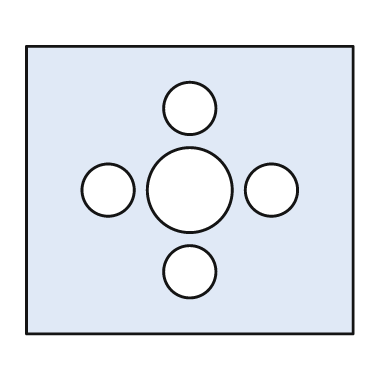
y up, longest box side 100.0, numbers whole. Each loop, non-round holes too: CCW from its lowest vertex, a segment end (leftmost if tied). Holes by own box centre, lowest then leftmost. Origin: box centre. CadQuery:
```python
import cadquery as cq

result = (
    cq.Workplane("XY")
    .moveTo(-50.0, -44.0)
    .lineTo(50.0, -44.0)
    .lineTo(50.0, 44.0)
    .lineTo(-50.0, 44.0)
    .close()
    .moveTo(0.0, -25.0)
    .circle(8.0)
    .moveTo(-25.0, 0.0)
    .circle(8.0)
    .moveTo(0.0, 0.0)
    .circle(13.0)
    .moveTo(25.0, 0.0)
    .circle(8.0)
    .moveTo(0.0, 25.0)
    .circle(8.0)
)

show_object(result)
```